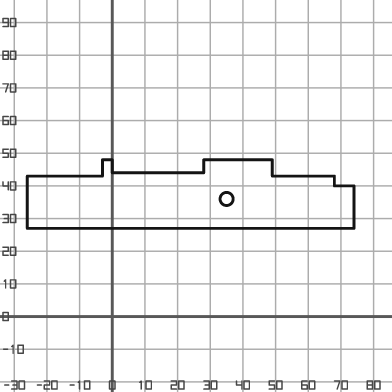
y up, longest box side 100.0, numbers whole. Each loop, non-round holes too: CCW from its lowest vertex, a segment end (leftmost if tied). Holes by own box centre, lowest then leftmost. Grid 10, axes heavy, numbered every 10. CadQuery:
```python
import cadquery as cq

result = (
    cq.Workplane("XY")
    .moveTo(-26.0, 27.0)
    .lineTo(74.0, 27.0)
    .lineTo(74.0, 40.0)
    .lineTo(68.0, 40.0)
    .lineTo(68.0, 43.0)
    .lineTo(49.0, 43.0)
    .lineTo(49.0, 48.0)
    .lineTo(28.0, 48.0)
    .lineTo(28.0, 44.0)
    .lineTo(0.0, 44.0)
    .lineTo(0.0, 48.0)
    .lineTo(-3.0, 48.0)
    .lineTo(-3.0, 43.0)
    .lineTo(-26.0, 43.0)
    .close()
    .moveTo(35.0, 36.0)
    .circle(2.0)
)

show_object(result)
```